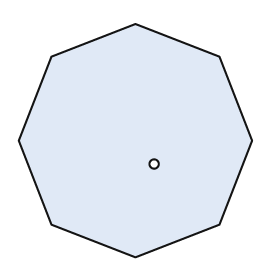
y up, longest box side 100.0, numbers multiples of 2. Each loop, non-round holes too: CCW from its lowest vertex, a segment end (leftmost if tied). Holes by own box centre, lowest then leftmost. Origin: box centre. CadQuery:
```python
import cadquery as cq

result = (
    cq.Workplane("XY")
    .moveTo(0.0, -50.0)
    .lineTo(36.0, -36.0)
    .lineTo(50.0, 0.0)
    .lineTo(36.0, 36.0)
    .lineTo(0.0, 50.0)
    .lineTo(-36.0, 36.0)
    .lineTo(-50.0, 0.0)
    .lineTo(-36.0, -36.0)
    .close()
    .moveTo(8.0, -10.0)
    .circle(2.0)
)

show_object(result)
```